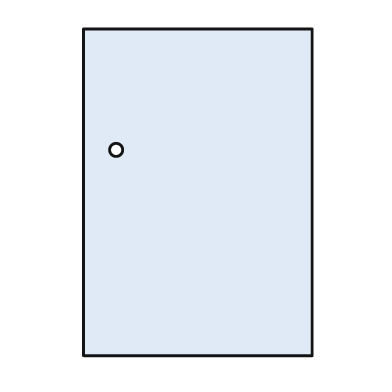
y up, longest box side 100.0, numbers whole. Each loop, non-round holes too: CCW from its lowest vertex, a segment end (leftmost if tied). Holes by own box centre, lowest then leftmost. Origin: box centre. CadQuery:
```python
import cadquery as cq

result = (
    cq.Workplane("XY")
    .moveTo(-35.0, -50.0)
    .lineTo(35.0, -50.0)
    .lineTo(35.0, 50.0)
    .lineTo(-35.0, 50.0)
    .close()
    .moveTo(-25.0, 13.0)
    .circle(2.0)
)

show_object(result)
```